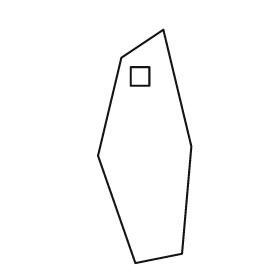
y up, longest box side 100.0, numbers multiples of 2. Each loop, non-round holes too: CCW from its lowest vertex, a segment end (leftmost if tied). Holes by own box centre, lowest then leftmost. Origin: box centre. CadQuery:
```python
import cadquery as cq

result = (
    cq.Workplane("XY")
    .moveTo(-4.0, -50.0)
    .lineTo(16.0, -46.0)
    .lineTo(20.0, 0.0)
    .lineTo(8.0, 50.0)
    .lineTo(-10.0, 38.0)
    .lineTo(-20.0, -4.0)
    .close()
    .moveTo(-6.0, 26.0)
    .lineTo(2.0, 26.0)
    .lineTo(2.0, 34.0)
    .lineTo(-6.0, 34.0)
    .close()
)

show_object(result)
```